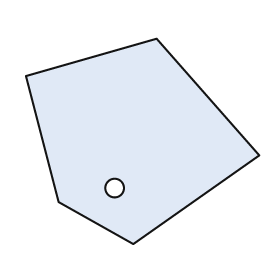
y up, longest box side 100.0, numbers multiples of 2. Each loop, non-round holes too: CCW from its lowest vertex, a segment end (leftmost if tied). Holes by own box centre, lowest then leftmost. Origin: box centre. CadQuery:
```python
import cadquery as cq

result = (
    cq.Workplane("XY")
    .moveTo(-4.0, -44.0)
    .lineTo(50.0, -6.0)
    .lineTo(6.0, 44.0)
    .lineTo(-50.0, 28.0)
    .lineTo(-36.0, -26.0)
    .close()
    .moveTo(-12.0, -20.0)
    .circle(4.0)
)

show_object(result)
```